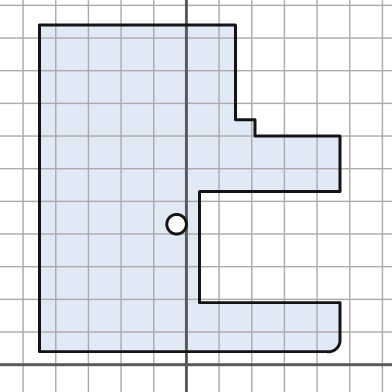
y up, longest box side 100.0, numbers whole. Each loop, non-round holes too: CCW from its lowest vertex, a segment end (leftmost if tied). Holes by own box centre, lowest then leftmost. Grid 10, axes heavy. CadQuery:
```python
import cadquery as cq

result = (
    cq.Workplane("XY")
    .moveTo(-45.0, 4.0)
    .lineTo(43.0, 4.0)
    .threePointArc((46.0, 5.0), (47.0, 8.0))
    .lineTo(47.0, 19.0)
    .lineTo(4.0, 19.0)
    .lineTo(4.0, 53.0)
    .lineTo(47.0, 53.0)
    .lineTo(47.0, 70.0)
    .lineTo(21.0, 70.0)
    .lineTo(21.0, 75.0)
    .lineTo(15.0, 75.0)
    .lineTo(15.0, 104.0)
    .lineTo(-45.0, 104.0)
    .close()
    .moveTo(-3.0, 43.0)
    .circle(3.0)
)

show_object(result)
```